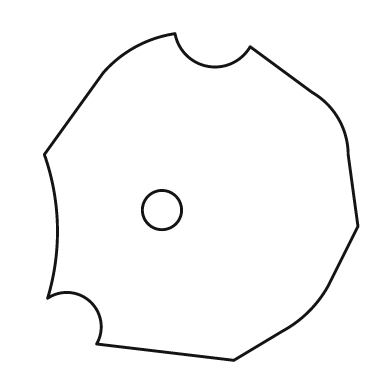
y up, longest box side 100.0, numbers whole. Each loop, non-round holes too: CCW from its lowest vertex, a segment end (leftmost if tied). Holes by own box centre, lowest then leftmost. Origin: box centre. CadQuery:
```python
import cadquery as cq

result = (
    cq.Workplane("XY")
    .moveTo(10.0, -50.0)
    .lineTo(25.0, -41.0)
    .threePointArc((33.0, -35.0), (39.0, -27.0))
    .lineTo(48.0, -9.0)
    .lineTo(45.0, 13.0)
    .threePointArc((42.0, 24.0), (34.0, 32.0))
    .lineTo(15.0, 46.0)
    .threePointArc((2.0, 40.0), (-8.0, 50.0))
    .threePointArc((-20.0, 46.0), (-30.0, 38.0))
    .lineTo(-48.0, 13.0)
    .threePointArc((-44.0, -9.0), (-47.0, -31.0))
    .threePointArc((-34.0, -32.0), (-32.0, -45.0))
    .close()
    .moveTo(-12.0, -4.0)
    .circle(6.0)
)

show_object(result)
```